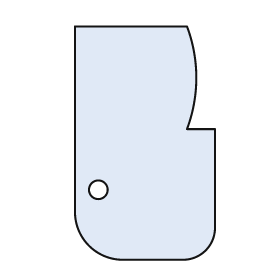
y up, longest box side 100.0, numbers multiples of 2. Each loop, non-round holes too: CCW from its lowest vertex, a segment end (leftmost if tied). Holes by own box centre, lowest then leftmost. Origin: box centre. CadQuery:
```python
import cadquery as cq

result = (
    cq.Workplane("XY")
    .moveTo(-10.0, -50.0)
    .lineTo(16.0, -50.0)
    .threePointArc((26.0, -46.0), (30.0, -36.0))
    .lineTo(30.0, 6.0)
    .lineTo(18.0, 6.0)
    .threePointArc((22.0, 28.0), (18.0, 50.0))
    .lineTo(-30.0, 50.0)
    .lineTo(-30.0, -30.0)
    .threePointArc((-24.0, -44.0), (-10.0, -50.0))
    .close()
    .moveTo(-20.0, -20.0)
    .circle(4.0)
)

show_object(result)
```